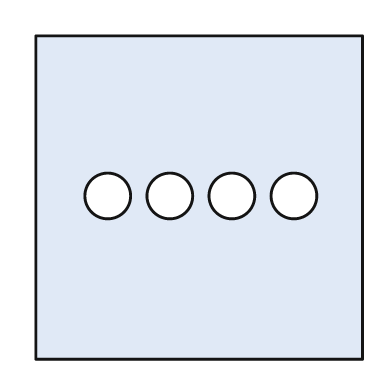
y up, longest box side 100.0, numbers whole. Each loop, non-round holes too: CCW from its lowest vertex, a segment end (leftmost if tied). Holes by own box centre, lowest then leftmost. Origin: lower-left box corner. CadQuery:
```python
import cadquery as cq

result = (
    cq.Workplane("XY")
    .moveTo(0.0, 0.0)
    .lineTo(100.0, 0.0)
    .lineTo(100.0, 99.0)
    .lineTo(0.0, 99.0)
    .close()
    .moveTo(22.0, 50.0)
    .circle(7.0)
    .moveTo(41.0, 50.0)
    .circle(7.0)
    .moveTo(60.0, 50.0)
    .circle(7.0)
    .moveTo(79.0, 50.0)
    .circle(7.0)
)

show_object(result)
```